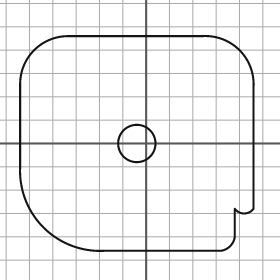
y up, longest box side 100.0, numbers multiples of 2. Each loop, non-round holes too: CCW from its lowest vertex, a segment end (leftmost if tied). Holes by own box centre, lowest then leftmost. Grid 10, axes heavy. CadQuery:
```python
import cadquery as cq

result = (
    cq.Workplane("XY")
    .moveTo(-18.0, -46.0)
    .lineTo(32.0, -46.0)
    .threePointArc((36.0, -44.0), (38.0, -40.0))
    .lineTo(38.0, -28.0)
    .threePointArc((42.0, -30.0), (46.0, -28.0))
    .lineTo(46.0, 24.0)
    .threePointArc((40.0, 40.0), (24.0, 46.0))
    .lineTo(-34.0, 46.0)
    .threePointArc((-48.0, 40.0), (-54.0, 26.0))
    .lineTo(-54.0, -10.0)
    .threePointArc((-44.0, -36.0), (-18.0, -46.0))
    .close()
    .moveTo(-4.0, 0.0)
    .circle(8.0)
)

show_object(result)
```